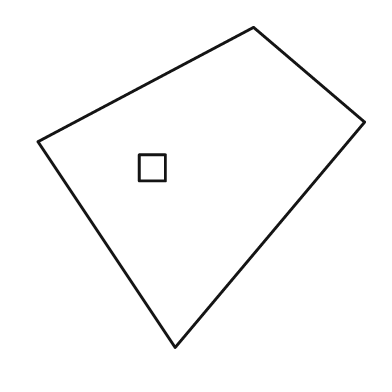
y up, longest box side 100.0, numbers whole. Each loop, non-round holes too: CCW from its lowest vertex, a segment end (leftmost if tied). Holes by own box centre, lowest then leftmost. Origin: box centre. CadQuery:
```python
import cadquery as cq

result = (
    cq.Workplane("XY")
    .moveTo(-8.0, -49.0)
    .lineTo(50.0, 20.0)
    .lineTo(16.0, 49.0)
    .lineTo(-50.0, 14.0)
    .close()
    .moveTo(-19.0, 2.0)
    .lineTo(-11.0, 2.0)
    .lineTo(-11.0, 10.0)
    .lineTo(-19.0, 10.0)
    .close()
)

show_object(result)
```